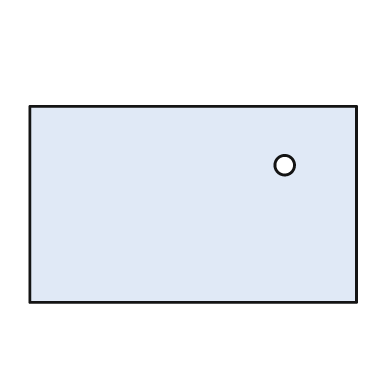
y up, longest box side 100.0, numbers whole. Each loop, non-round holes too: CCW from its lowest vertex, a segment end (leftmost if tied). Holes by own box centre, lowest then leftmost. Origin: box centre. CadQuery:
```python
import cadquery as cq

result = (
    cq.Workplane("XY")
    .moveTo(-50.0, -30.0)
    .lineTo(50.0, -30.0)
    .lineTo(50.0, 30.0)
    .lineTo(-50.0, 30.0)
    .close()
    .moveTo(28.0, 12.0)
    .circle(3.0)
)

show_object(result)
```